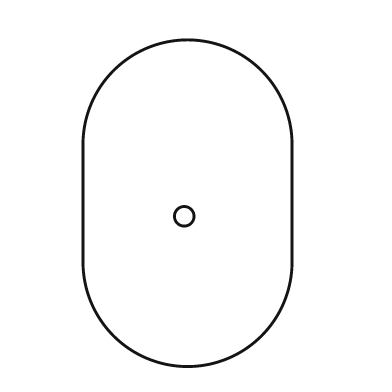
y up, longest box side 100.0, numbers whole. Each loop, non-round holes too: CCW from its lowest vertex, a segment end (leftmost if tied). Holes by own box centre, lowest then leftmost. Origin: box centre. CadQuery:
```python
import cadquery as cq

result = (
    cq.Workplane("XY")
    .moveTo(-32.0, -18.0)
    .threePointArc((0.0, -50.0), (32.0, -18.0))
    .lineTo(32.0, 18.0)
    .threePointArc((0.0, 50.0), (-32.0, 18.0))
    .close()
    .moveTo(-1.0, -4.0)
    .circle(3.0)
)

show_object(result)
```